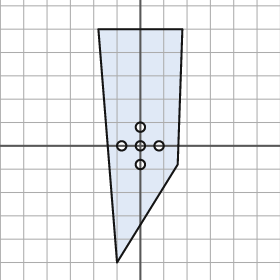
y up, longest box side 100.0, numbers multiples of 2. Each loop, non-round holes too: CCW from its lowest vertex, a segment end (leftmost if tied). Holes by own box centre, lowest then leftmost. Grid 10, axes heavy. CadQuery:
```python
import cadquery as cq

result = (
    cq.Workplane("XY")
    .moveTo(-10.0, -50.0)
    .lineTo(16.0, -8.0)
    .lineTo(18.0, 50.0)
    .lineTo(-18.0, 50.0)
    .close()
    .moveTo(0.0, -8.0)
    .circle(2.0)
    .moveTo(-8.0, 0.0)
    .circle(2.0)
    .moveTo(0.0, 0.0)
    .circle(2.0)
    .moveTo(8.0, 0.0)
    .circle(2.0)
    .moveTo(0.0, 8.0)
    .circle(2.0)
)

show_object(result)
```